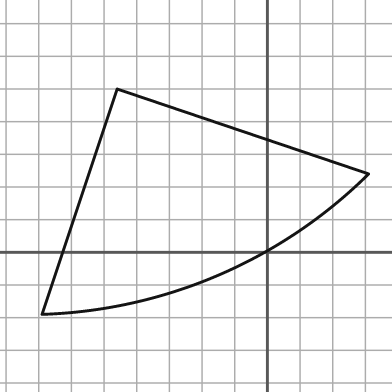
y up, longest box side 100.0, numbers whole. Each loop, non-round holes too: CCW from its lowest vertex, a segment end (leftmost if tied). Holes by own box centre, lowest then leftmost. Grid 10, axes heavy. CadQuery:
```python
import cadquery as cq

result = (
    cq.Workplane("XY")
    .moveTo(-69.0, -19.0)
    .threePointArc((-15.0, -7.0), (31.0, 24.0))
    .lineTo(-46.0, 50.0)
    .close()
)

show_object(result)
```